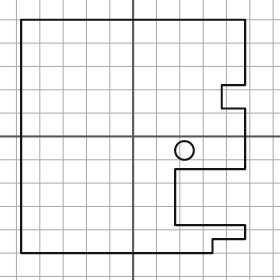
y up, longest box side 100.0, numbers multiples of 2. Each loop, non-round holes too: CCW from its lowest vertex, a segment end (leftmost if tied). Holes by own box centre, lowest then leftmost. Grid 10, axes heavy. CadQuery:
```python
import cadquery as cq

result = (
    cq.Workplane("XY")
    .moveTo(-48.0, -50.0)
    .lineTo(34.0, -50.0)
    .lineTo(34.0, -44.0)
    .lineTo(48.0, -44.0)
    .lineTo(48.0, -38.0)
    .lineTo(18.0, -38.0)
    .lineTo(18.0, -14.0)
    .lineTo(48.0, -14.0)
    .lineTo(48.0, 12.0)
    .lineTo(38.0, 12.0)
    .lineTo(38.0, 22.0)
    .lineTo(48.0, 22.0)
    .lineTo(48.0, 50.0)
    .lineTo(-48.0, 50.0)
    .close()
    .moveTo(22.0, -6.0)
    .circle(4.0)
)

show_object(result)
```